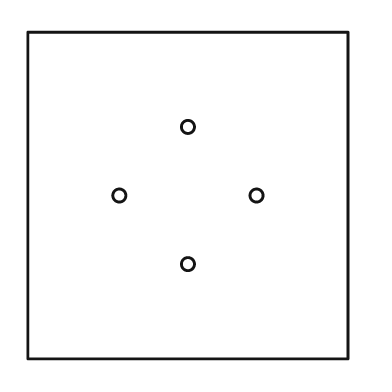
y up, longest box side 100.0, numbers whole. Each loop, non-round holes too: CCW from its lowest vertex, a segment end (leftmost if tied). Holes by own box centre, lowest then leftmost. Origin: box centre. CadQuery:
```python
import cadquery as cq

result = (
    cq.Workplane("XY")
    .moveTo(-49.0, -50.0)
    .lineTo(49.0, -50.0)
    .lineTo(49.0, 50.0)
    .lineTo(-49.0, 50.0)
    .close()
    .moveTo(0.0, -21.0)
    .circle(2.0)
    .moveTo(-21.0, 0.0)
    .circle(2.0)
    .moveTo(21.0, 0.0)
    .circle(2.0)
    .moveTo(0.0, 21.0)
    .circle(2.0)
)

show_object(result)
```